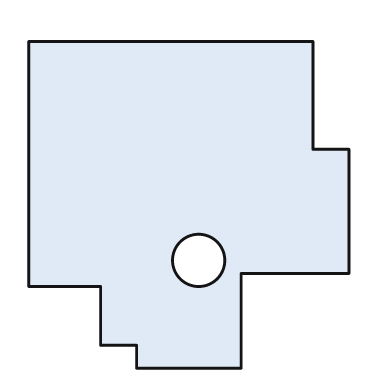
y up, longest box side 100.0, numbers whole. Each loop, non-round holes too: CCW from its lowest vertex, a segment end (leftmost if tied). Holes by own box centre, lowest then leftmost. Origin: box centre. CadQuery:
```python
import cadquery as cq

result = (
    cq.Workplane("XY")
    .moveTo(-16.0, -50.0)
    .lineTo(16.0, -50.0)
    .lineTo(16.0, -21.0)
    .lineTo(49.0, -21.0)
    .lineTo(49.0, 17.0)
    .lineTo(38.0, 17.0)
    .lineTo(38.0, 50.0)
    .lineTo(-49.0, 50.0)
    .lineTo(-49.0, -25.0)
    .lineTo(-27.0, -25.0)
    .lineTo(-27.0, -43.0)
    .lineTo(-16.0, -43.0)
    .close()
    .moveTo(3.0, -17.0)
    .circle(8.0)
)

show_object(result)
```